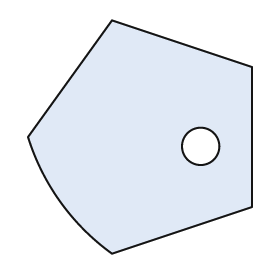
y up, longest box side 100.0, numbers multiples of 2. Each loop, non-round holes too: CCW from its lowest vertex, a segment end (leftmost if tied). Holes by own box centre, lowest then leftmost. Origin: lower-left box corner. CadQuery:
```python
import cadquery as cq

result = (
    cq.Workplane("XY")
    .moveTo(36.0, 0.0)
    .lineTo(96.0, 20.0)
    .lineTo(96.0, 80.0)
    .lineTo(36.0, 100.0)
    .lineTo(0.0, 50.0)
    .threePointArc((14.0, 22.0), (36.0, 0.0))
    .close()
    .moveTo(74.0, 46.0)
    .circle(8.0)
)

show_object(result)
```